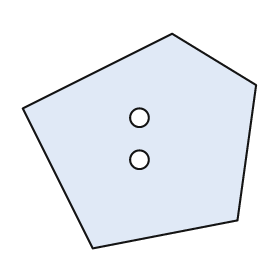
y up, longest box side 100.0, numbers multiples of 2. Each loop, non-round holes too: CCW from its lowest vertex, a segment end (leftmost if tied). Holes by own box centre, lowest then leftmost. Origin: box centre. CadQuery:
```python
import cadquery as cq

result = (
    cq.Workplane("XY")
    .moveTo(-20.0, -46.0)
    .lineTo(42.0, -34.0)
    .lineTo(50.0, 24.0)
    .lineTo(14.0, 46.0)
    .lineTo(-50.0, 14.0)
    .close()
    .moveTo(0.0, -8.0)
    .circle(4.0)
    .moveTo(0.0, 10.0)
    .circle(4.0)
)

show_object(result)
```